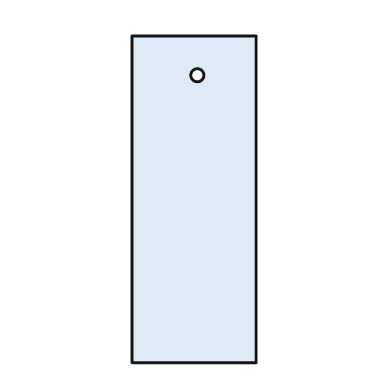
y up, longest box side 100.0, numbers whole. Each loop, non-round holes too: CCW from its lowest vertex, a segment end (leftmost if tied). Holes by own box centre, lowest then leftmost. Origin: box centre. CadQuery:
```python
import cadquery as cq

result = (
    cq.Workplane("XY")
    .moveTo(-19.0, -50.0)
    .lineTo(19.0, -50.0)
    .lineTo(19.0, 50.0)
    .lineTo(-19.0, 50.0)
    .close()
    .moveTo(1.0, 38.0)
    .circle(2.0)
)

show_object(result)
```